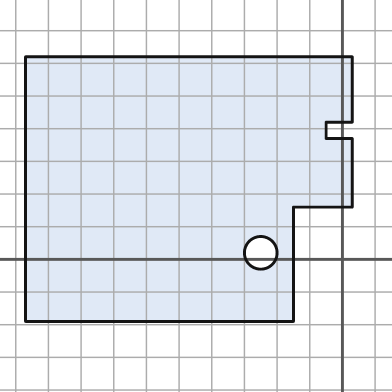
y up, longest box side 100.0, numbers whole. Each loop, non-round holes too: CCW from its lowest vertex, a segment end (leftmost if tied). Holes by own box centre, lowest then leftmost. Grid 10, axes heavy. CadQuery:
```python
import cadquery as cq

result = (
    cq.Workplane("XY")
    .moveTo(-97.0, -19.0)
    .lineTo(-15.0, -19.0)
    .lineTo(-15.0, 16.0)
    .lineTo(3.0, 16.0)
    .lineTo(3.0, 37.0)
    .lineTo(-5.0, 37.0)
    .lineTo(-5.0, 42.0)
    .lineTo(3.0, 42.0)
    .lineTo(3.0, 62.0)
    .lineTo(-97.0, 62.0)
    .close()
    .moveTo(-25.0, 2.0)
    .circle(5.0)
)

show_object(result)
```